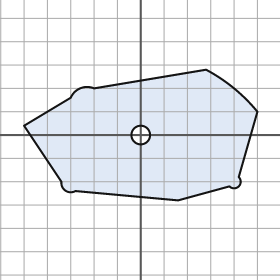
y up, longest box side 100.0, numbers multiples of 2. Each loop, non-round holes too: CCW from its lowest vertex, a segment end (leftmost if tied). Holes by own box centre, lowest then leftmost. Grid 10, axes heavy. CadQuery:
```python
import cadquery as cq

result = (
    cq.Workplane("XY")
    .moveTo(16.0, -28.0)
    .lineTo(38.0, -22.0)
    .threePointArc((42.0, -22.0), (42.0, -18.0))
    .lineTo(50.0, 10.0)
    .threePointArc((40.0, 20.0), (28.0, 28.0))
    .lineTo(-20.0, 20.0)
    .threePointArc((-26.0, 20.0), (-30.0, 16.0))
    .lineTo(-50.0, 4.0)
    .lineTo(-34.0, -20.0)
    .threePointArc((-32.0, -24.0), (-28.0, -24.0))
    .close()
    .moveTo(0.0, 0.0)
    .circle(4.0)
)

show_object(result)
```